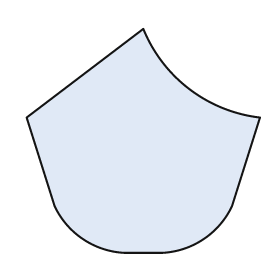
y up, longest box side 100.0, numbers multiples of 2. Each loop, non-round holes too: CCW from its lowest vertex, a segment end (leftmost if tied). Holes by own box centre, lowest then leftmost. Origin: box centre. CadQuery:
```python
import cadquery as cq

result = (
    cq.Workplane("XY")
    .moveTo(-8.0, -48.0)
    .lineTo(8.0, -48.0)
    .threePointArc((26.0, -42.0), (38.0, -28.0))
    .lineTo(50.0, 10.0)
    .threePointArc((20.0, 22.0), (0.0, 48.0))
    .lineTo(-50.0, 10.0)
    .lineTo(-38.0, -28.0)
    .threePointArc((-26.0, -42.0), (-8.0, -48.0))
    .close()
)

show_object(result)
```